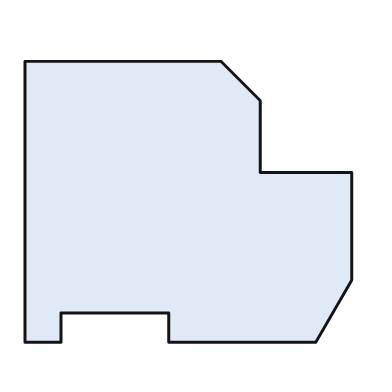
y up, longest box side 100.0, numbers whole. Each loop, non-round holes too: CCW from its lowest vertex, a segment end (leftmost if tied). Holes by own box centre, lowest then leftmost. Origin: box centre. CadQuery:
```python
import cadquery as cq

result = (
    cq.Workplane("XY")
    .moveTo(-50.0, -43.0)
    .lineTo(-39.0, -43.0)
    .lineTo(-39.0, -34.0)
    .lineTo(-6.0, -34.0)
    .lineTo(-6.0, -43.0)
    .lineTo(39.0, -43.0)
    .lineTo(50.0, -24.0)
    .lineTo(50.0, 9.0)
    .lineTo(22.0, 9.0)
    .lineTo(22.0, 31.0)
    .lineTo(10.0, 43.0)
    .lineTo(-50.0, 43.0)
    .close()
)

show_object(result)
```